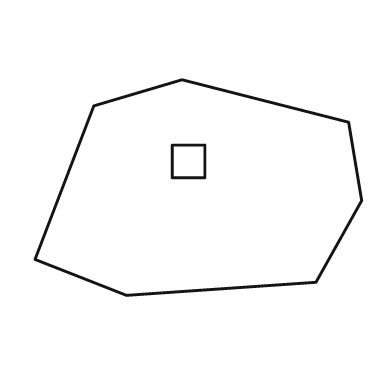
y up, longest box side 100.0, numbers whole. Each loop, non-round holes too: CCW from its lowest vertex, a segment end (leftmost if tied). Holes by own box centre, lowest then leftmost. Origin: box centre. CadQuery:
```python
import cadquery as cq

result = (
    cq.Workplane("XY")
    .moveTo(-22.0, -33.0)
    .lineTo(36.0, -29.0)
    .lineTo(50.0, -4.0)
    .lineTo(46.0, 20.0)
    .lineTo(-5.0, 33.0)
    .lineTo(-32.0, 25.0)
    .lineTo(-50.0, -22.0)
    .close()
    .moveTo(-8.0, 3.0)
    .lineTo(2.0, 3.0)
    .lineTo(2.0, 13.0)
    .lineTo(-8.0, 13.0)
    .close()
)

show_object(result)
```